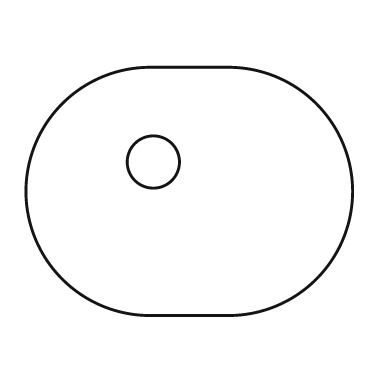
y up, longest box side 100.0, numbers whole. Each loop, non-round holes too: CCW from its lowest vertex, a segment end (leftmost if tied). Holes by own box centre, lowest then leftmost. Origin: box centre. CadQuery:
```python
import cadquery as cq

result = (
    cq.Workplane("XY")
    .moveTo(-12.0, -38.0)
    .lineTo(12.0, -38.0)
    .threePointArc((50.0, 0.0), (12.0, 38.0))
    .lineTo(-12.0, 38.0)
    .threePointArc((-50.0, 0.0), (-12.0, -38.0))
    .close()
    .moveTo(-11.0, 9.0)
    .circle(8.0)
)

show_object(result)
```